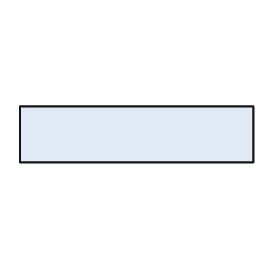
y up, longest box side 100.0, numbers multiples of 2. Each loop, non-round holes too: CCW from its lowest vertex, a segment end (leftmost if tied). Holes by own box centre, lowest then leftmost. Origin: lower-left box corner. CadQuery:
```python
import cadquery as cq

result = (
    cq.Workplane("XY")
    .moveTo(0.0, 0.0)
    .lineTo(100.0, 0.0)
    .lineTo(100.0, 24.0)
    .lineTo(0.0, 24.0)
    .close()
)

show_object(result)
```